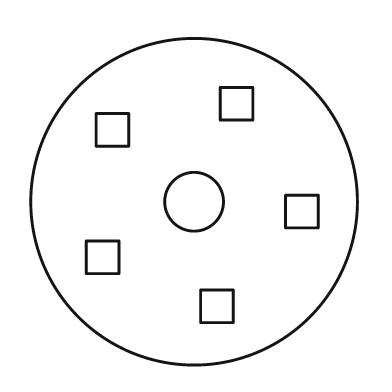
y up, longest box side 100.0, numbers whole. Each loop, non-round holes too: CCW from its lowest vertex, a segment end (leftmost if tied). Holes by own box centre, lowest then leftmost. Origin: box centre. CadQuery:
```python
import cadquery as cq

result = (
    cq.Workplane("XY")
    .moveTo(0.0, 0.0)
    .circle(50.0)
    .moveTo(2.0, -37.0)
    .lineTo(12.0, -37.0)
    .lineTo(12.0, -27.0)
    .lineTo(2.0, -27.0)
    .close()
    .moveTo(-33.0, -22.0)
    .lineTo(-23.0, -22.0)
    .lineTo(-23.0, -12.0)
    .lineTo(-33.0, -12.0)
    .close()
    .moveTo(28.0, -8.0)
    .lineTo(38.0, -8.0)
    .lineTo(38.0, 2.0)
    .lineTo(28.0, 2.0)
    .close()
    .moveTo(0.0, 0.0)
    .circle(9.0)
    .moveTo(-30.0, 17.0)
    .lineTo(-20.0, 17.0)
    .lineTo(-20.0, 27.0)
    .lineTo(-30.0, 27.0)
    .close()
    .moveTo(8.0, 25.0)
    .lineTo(18.0, 25.0)
    .lineTo(18.0, 35.0)
    .lineTo(8.0, 35.0)
    .close()
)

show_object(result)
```